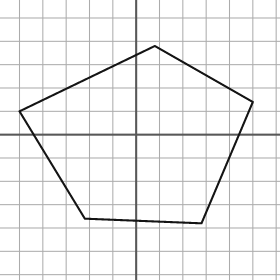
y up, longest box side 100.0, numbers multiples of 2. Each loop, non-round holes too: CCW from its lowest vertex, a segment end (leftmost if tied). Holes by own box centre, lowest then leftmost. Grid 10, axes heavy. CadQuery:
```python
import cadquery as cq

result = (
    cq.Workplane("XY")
    .moveTo(28.0, -38.0)
    .lineTo(50.0, 14.0)
    .lineTo(8.0, 38.0)
    .lineTo(-50.0, 10.0)
    .lineTo(-22.0, -36.0)
    .close()
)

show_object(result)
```